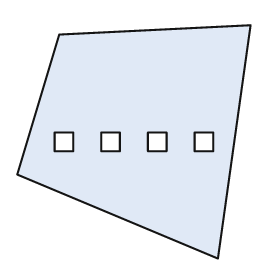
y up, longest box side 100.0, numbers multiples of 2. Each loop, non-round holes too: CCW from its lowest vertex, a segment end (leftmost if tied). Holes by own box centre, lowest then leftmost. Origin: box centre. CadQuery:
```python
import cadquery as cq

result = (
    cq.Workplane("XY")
    .moveTo(36.0, -50.0)
    .lineTo(50.0, 50.0)
    .lineTo(-32.0, 46.0)
    .lineTo(-50.0, -14.0)
    .close()
    .moveTo(-34.0, -4.0)
    .lineTo(-26.0, -4.0)
    .lineTo(-26.0, 4.0)
    .lineTo(-34.0, 4.0)
    .close()
    .moveTo(-14.0, -4.0)
    .lineTo(-6.0, -4.0)
    .lineTo(-6.0, 4.0)
    .lineTo(-14.0, 4.0)
    .close()
    .moveTo(6.0, -4.0)
    .lineTo(14.0, -4.0)
    .lineTo(14.0, 4.0)
    .lineTo(6.0, 4.0)
    .close()
    .moveTo(26.0, -4.0)
    .lineTo(34.0, -4.0)
    .lineTo(34.0, 4.0)
    .lineTo(26.0, 4.0)
    .close()
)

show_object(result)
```